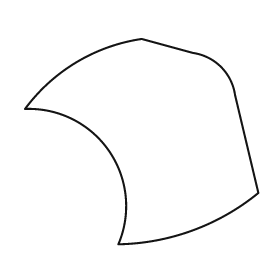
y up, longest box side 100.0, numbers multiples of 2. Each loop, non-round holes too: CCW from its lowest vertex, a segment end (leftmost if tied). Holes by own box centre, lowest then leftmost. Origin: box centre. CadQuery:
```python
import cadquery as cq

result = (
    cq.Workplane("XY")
    .moveTo(-10.0, -44.0)
    .threePointArc((22.0, -38.0), (50.0, -22.0))
    .lineTo(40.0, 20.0)
    .threePointArc((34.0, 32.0), (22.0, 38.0))
    .lineTo(0.0, 44.0)
    .threePointArc((-28.0, 34.0), (-50.0, 14.0))
    .threePointArc((-14.0, -4.0), (-10.0, -44.0))
    .close()
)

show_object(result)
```